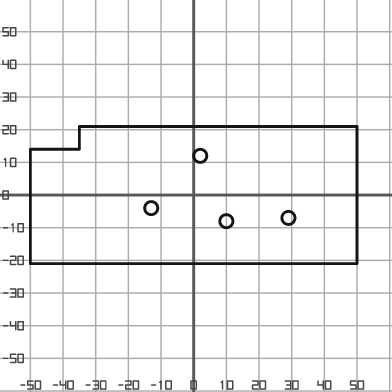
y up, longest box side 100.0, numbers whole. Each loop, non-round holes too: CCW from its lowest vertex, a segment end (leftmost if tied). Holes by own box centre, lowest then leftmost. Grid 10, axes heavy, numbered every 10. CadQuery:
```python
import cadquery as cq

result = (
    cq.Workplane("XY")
    .moveTo(-50.0, -21.0)
    .lineTo(50.0, -21.0)
    .lineTo(50.0, 21.0)
    .lineTo(-35.0, 21.0)
    .lineTo(-35.0, 14.0)
    .lineTo(-50.0, 14.0)
    .close()
    .moveTo(10.0, -8.0)
    .circle(2.0)
    .moveTo(29.0, -7.0)
    .circle(2.0)
    .moveTo(-13.0, -4.0)
    .circle(2.0)
    .moveTo(2.0, 12.0)
    .circle(2.0)
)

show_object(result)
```